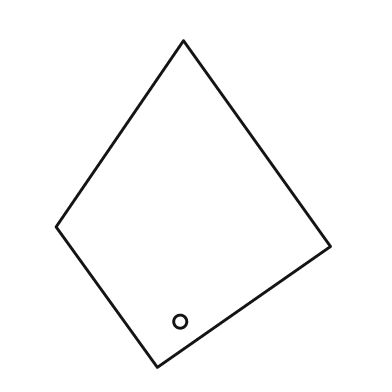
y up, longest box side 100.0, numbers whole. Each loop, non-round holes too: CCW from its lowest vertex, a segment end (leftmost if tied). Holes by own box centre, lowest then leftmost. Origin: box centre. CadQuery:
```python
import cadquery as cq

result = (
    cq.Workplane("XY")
    .moveTo(-11.0, -50.0)
    .lineTo(42.0, -13.0)
    .lineTo(-3.0, 50.0)
    .lineTo(-42.0, -7.0)
    .close()
    .moveTo(-4.0, -36.0)
    .circle(2.0)
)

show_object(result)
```